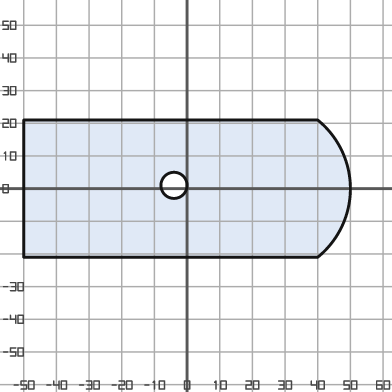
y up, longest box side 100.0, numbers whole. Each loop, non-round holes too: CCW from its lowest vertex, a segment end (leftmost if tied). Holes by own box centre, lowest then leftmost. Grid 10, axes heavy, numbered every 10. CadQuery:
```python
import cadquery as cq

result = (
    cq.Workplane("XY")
    .moveTo(-50.0, -21.0)
    .lineTo(40.0, -21.0)
    .threePointArc((50.0, 0.0), (40.0, 21.0))
    .lineTo(-50.0, 21.0)
    .close()
    .moveTo(-4.0, 1.0)
    .circle(4.0)
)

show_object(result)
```